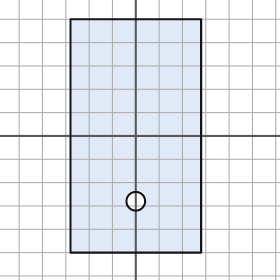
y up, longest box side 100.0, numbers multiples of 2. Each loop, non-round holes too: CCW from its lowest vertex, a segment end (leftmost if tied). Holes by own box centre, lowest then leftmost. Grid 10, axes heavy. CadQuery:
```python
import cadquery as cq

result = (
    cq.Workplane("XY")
    .moveTo(-28.0, -50.0)
    .lineTo(28.0, -50.0)
    .lineTo(28.0, 50.0)
    .lineTo(-28.0, 50.0)
    .close()
    .moveTo(0.0, -28.0)
    .circle(4.0)
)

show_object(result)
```